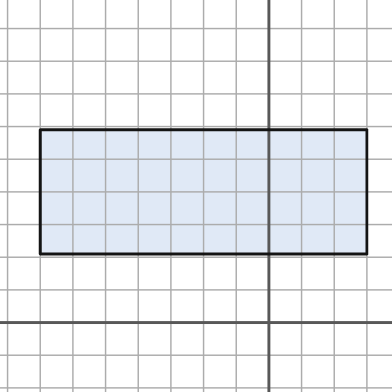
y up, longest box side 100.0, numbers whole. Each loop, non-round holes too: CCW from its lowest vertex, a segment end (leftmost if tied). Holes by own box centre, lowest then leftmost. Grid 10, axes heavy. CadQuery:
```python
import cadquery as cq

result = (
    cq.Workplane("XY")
    .moveTo(-70.0, 21.0)
    .lineTo(30.0, 21.0)
    .lineTo(30.0, 59.0)
    .lineTo(-70.0, 59.0)
    .close()
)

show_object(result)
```